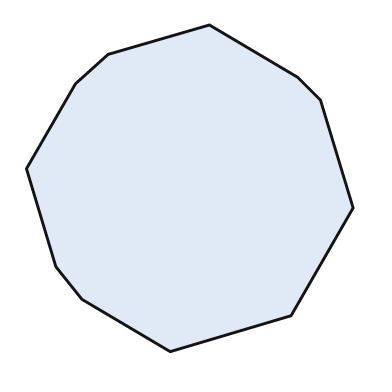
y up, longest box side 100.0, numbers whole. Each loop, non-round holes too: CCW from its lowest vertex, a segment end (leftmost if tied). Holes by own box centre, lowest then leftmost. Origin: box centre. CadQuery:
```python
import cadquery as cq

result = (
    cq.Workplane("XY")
    .moveTo(-6.0, -50.0)
    .lineTo(31.0, -39.0)
    .lineTo(50.0, -6.0)
    .lineTo(40.0, 27.0)
    .lineTo(33.0, 34.0)
    .lineTo(6.0, 50.0)
    .lineTo(-25.0, 41.0)
    .lineTo(-35.0, 32.0)
    .lineTo(-50.0, 6.0)
    .lineTo(-41.0, -24.0)
    .lineTo(-33.0, -34.0)
    .close()
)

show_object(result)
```